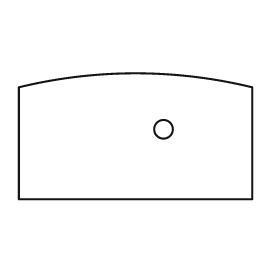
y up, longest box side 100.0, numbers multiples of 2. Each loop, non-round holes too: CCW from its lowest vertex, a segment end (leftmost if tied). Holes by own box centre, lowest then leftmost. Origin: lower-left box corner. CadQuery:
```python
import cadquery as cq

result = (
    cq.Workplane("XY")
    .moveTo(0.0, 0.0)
    .lineTo(100.0, 0.0)
    .lineTo(100.0, 48.0)
    .threePointArc((50.0, 54.0), (0.0, 48.0))
    .close()
    .moveTo(62.0, 30.0)
    .circle(4.0)
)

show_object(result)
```